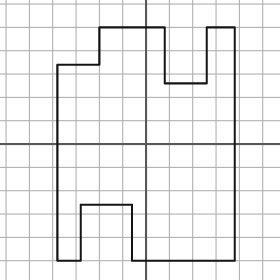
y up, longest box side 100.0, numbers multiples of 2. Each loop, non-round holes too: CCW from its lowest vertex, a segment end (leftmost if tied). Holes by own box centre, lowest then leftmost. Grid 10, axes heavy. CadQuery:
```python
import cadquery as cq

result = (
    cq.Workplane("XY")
    .moveTo(-38.0, -50.0)
    .lineTo(-28.0, -50.0)
    .lineTo(-28.0, -26.0)
    .lineTo(-6.0, -26.0)
    .lineTo(-6.0, -50.0)
    .lineTo(38.0, -50.0)
    .lineTo(38.0, 50.0)
    .lineTo(26.0, 50.0)
    .lineTo(26.0, 26.0)
    .lineTo(8.0, 26.0)
    .lineTo(8.0, 50.0)
    .lineTo(-20.0, 50.0)
    .lineTo(-20.0, 34.0)
    .lineTo(-38.0, 34.0)
    .close()
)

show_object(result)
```